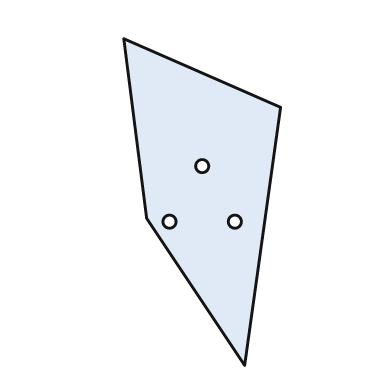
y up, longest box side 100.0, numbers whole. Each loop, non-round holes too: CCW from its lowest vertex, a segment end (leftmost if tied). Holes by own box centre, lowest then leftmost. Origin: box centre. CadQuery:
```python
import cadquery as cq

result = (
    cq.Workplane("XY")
    .moveTo(13.0, -50.0)
    .lineTo(24.0, 29.0)
    .lineTo(-24.0, 50.0)
    .lineTo(-17.0, -5.0)
    .close()
    .moveTo(-10.0, -6.0)
    .circle(2.0)
    .moveTo(10.0, -6.0)
    .circle(2.0)
    .moveTo(0.0, 11.0)
    .circle(2.0)
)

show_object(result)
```